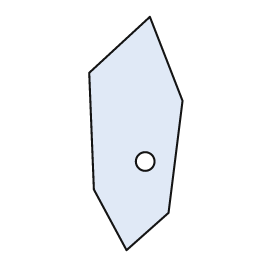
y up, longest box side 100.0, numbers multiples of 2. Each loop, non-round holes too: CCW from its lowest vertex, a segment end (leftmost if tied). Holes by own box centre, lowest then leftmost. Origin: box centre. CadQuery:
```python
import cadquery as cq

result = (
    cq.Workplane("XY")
    .moveTo(-4.0, -50.0)
    .lineTo(14.0, -34.0)
    .lineTo(20.0, 14.0)
    .lineTo(6.0, 50.0)
    .lineTo(-20.0, 26.0)
    .lineTo(-18.0, -24.0)
    .close()
    .moveTo(4.0, -12.0)
    .circle(4.0)
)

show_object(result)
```